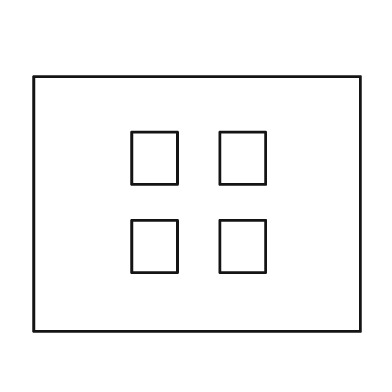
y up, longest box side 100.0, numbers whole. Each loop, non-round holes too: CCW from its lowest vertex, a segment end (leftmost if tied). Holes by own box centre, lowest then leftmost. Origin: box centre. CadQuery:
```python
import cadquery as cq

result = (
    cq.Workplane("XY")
    .moveTo(-50.0, -39.0)
    .lineTo(50.0, -39.0)
    .lineTo(50.0, 39.0)
    .lineTo(-50.0, 39.0)
    .close()
    .moveTo(-20.0, -21.0)
    .lineTo(-6.0, -21.0)
    .lineTo(-6.0, -5.0)
    .lineTo(-20.0, -5.0)
    .close()
    .moveTo(7.0, -21.0)
    .lineTo(21.0, -21.0)
    .lineTo(21.0, -5.0)
    .lineTo(7.0, -5.0)
    .close()
    .moveTo(-20.0, 6.0)
    .lineTo(-6.0, 6.0)
    .lineTo(-6.0, 22.0)
    .lineTo(-20.0, 22.0)
    .close()
    .moveTo(7.0, 6.0)
    .lineTo(21.0, 6.0)
    .lineTo(21.0, 22.0)
    .lineTo(7.0, 22.0)
    .close()
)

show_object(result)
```